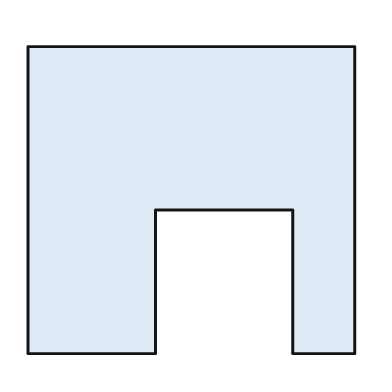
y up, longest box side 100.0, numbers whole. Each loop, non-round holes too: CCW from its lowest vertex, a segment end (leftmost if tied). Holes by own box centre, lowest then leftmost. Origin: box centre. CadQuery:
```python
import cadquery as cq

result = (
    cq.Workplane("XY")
    .moveTo(-50.0, -47.0)
    .lineTo(-11.0, -47.0)
    .lineTo(-11.0, -3.0)
    .lineTo(31.0, -3.0)
    .lineTo(31.0, -47.0)
    .lineTo(50.0, -47.0)
    .lineTo(50.0, 47.0)
    .lineTo(-50.0, 47.0)
    .close()
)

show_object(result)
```